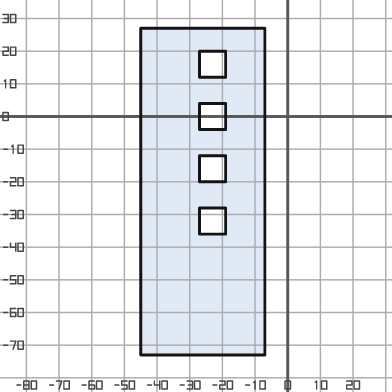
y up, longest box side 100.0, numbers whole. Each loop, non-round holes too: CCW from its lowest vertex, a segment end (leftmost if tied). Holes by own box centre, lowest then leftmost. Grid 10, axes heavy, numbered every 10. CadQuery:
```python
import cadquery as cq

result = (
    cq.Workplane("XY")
    .moveTo(-45.0, -73.0)
    .lineTo(-7.0, -73.0)
    .lineTo(-7.0, 27.0)
    .lineTo(-45.0, 27.0)
    .close()
    .moveTo(-27.0, -36.0)
    .lineTo(-19.0, -36.0)
    .lineTo(-19.0, -28.0)
    .lineTo(-27.0, -28.0)
    .close()
    .moveTo(-27.0, -20.0)
    .lineTo(-19.0, -20.0)
    .lineTo(-19.0, -12.0)
    .lineTo(-27.0, -12.0)
    .close()
    .moveTo(-27.0, -4.0)
    .lineTo(-19.0, -4.0)
    .lineTo(-19.0, 4.0)
    .lineTo(-27.0, 4.0)
    .close()
    .moveTo(-27.0, 12.0)
    .lineTo(-19.0, 12.0)
    .lineTo(-19.0, 20.0)
    .lineTo(-27.0, 20.0)
    .close()
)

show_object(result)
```